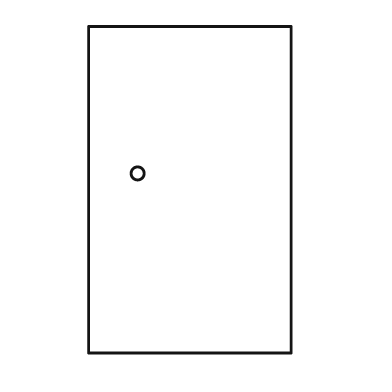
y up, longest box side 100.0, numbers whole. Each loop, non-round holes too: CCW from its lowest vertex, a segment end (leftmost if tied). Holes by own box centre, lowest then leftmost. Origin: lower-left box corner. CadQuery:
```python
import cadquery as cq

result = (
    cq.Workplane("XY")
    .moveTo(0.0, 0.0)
    .lineTo(62.0, 0.0)
    .lineTo(62.0, 100.0)
    .lineTo(0.0, 100.0)
    .close()
    .moveTo(15.0, 55.0)
    .circle(2.0)
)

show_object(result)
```